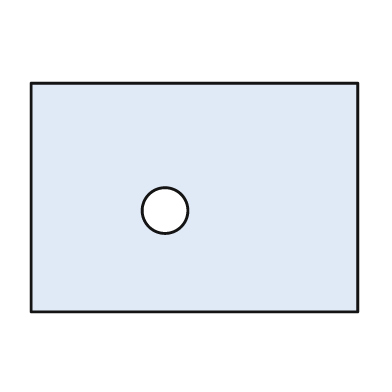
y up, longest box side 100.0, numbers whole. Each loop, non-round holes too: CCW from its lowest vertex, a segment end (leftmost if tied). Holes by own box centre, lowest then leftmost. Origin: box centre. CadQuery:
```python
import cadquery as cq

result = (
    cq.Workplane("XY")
    .moveTo(-50.0, -35.0)
    .lineTo(50.0, -35.0)
    .lineTo(50.0, 35.0)
    .lineTo(-50.0, 35.0)
    .close()
    .moveTo(-9.0, -4.0)
    .circle(7.0)
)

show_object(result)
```